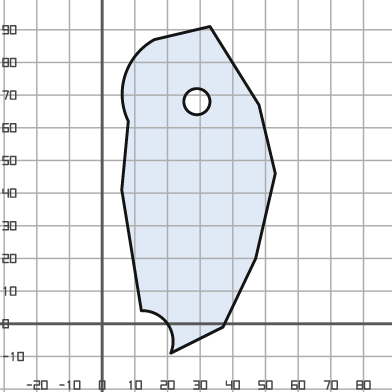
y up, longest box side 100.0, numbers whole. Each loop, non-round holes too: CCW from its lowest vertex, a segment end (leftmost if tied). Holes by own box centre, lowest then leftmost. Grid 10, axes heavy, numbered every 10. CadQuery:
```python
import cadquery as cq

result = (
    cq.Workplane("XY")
    .moveTo(21.0, -9.0)
    .lineTo(37.0, -1.0)
    .lineTo(47.0, 20.0)
    .lineTo(53.0, 46.0)
    .lineTo(48.0, 67.0)
    .lineTo(33.0, 91.0)
    .lineTo(16.0, 87.0)
    .threePointArc((7.0, 76.0), (8.0, 62.0))
    .lineTo(6.0, 41.0)
    .lineTo(12.0, 4.0)
    .threePointArc((20.0, 0.0), (21.0, -9.0))
    .close()
    .moveTo(29.0, 68.0)
    .circle(4.0)
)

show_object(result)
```